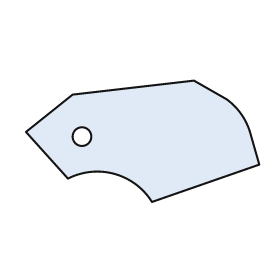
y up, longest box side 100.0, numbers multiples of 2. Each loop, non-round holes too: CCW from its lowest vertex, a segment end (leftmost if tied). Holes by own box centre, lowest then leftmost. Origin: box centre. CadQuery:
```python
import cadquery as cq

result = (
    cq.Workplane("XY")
    .moveTo(4.0, -26.0)
    .lineTo(50.0, -10.0)
    .lineTo(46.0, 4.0)
    .threePointArc((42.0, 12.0), (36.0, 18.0))
    .lineTo(22.0, 26.0)
    .lineTo(-30.0, 20.0)
    .lineTo(-50.0, 4.0)
    .lineTo(-32.0, -16.0)
    .threePointArc((-12.0, -14.0), (4.0, -26.0))
    .close()
    .moveTo(-26.0, 2.0)
    .circle(4.0)
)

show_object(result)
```